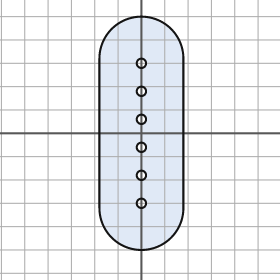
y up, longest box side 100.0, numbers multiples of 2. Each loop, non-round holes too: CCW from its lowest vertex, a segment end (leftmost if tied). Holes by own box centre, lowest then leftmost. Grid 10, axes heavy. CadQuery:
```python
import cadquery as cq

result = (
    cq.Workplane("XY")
    .moveTo(-18.0, -32.0)
    .threePointArc((0.0, -50.0), (18.0, -32.0))
    .lineTo(18.0, 32.0)
    .threePointArc((0.0, 50.0), (-18.0, 32.0))
    .close()
    .moveTo(0.0, -30.0)
    .circle(2.0)
    .moveTo(0.0, -18.0)
    .circle(2.0)
    .moveTo(0.0, -6.0)
    .circle(2.0)
    .moveTo(0.0, 6.0)
    .circle(2.0)
    .moveTo(0.0, 18.0)
    .circle(2.0)
    .moveTo(0.0, 30.0)
    .circle(2.0)
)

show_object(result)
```